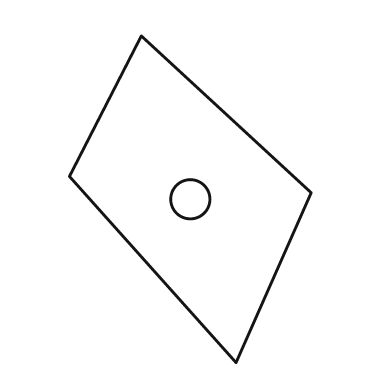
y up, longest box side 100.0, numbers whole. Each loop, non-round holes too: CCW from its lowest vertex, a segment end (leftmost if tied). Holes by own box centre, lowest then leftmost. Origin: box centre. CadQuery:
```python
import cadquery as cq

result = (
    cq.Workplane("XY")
    .moveTo(14.0, -50.0)
    .lineTo(37.0, 2.0)
    .lineTo(-15.0, 50.0)
    .lineTo(-37.0, 7.0)
    .close()
    .moveTo(0.0, 0.0)
    .circle(6.0)
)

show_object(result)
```